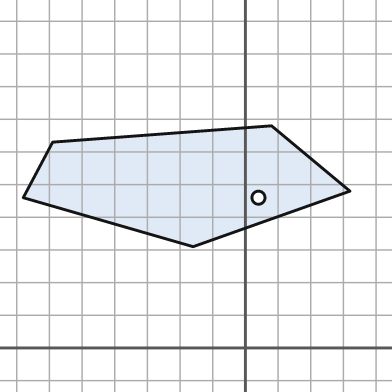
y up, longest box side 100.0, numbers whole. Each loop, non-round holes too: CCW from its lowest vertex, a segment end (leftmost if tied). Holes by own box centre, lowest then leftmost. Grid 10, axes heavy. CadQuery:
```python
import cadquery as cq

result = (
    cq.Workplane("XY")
    .moveTo(-16.0, 31.0)
    .lineTo(32.0, 48.0)
    .lineTo(8.0, 68.0)
    .lineTo(-59.0, 63.0)
    .lineTo(-68.0, 46.0)
    .close()
    .moveTo(4.0, 46.0)
    .circle(2.0)
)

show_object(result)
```